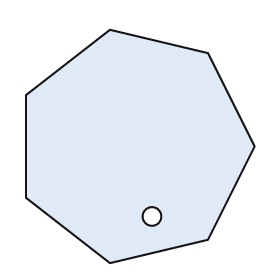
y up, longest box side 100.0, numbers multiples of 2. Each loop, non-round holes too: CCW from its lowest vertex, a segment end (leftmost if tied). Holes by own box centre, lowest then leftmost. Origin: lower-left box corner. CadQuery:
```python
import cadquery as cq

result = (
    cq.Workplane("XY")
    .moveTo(36.0, 0.0)
    .lineTo(78.0, 10.0)
    .lineTo(98.0, 50.0)
    .lineTo(78.0, 90.0)
    .lineTo(36.0, 100.0)
    .lineTo(0.0, 72.0)
    .lineTo(0.0, 28.0)
    .close()
    .moveTo(54.0, 20.0)
    .circle(4.0)
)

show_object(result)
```